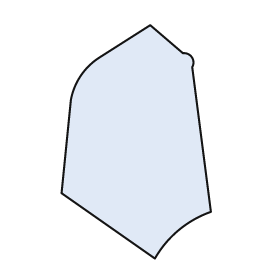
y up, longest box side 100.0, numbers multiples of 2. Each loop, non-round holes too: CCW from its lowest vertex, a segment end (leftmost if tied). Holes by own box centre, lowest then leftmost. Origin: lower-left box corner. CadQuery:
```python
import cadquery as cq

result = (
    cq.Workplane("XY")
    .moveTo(40.0, 0.0)
    .threePointArc((50.0, 12.0), (64.0, 20.0))
    .lineTo(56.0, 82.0)
    .threePointArc((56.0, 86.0), (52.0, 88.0))
    .lineTo(38.0, 100.0)
    .lineTo(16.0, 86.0)
    .threePointArc((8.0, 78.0), (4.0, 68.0))
    .lineTo(0.0, 28.0)
    .close()
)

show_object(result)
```